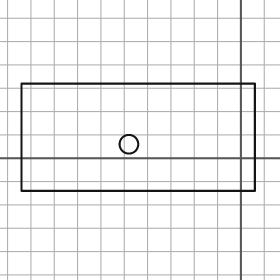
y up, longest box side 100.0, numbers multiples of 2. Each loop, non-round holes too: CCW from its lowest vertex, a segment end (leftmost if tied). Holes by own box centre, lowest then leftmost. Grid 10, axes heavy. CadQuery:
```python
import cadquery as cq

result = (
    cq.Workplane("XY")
    .moveTo(-94.0, -14.0)
    .lineTo(6.0, -14.0)
    .lineTo(6.0, 32.0)
    .lineTo(-94.0, 32.0)
    .close()
    .moveTo(-48.0, 6.0)
    .circle(4.0)
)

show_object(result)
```